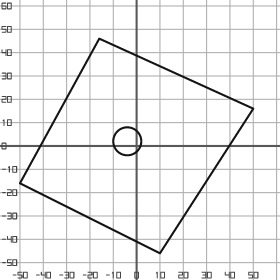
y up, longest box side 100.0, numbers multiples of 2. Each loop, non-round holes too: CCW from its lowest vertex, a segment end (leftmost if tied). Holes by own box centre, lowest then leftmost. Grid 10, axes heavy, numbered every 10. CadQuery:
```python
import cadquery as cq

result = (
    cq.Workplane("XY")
    .moveTo(10.0, -46.0)
    .lineTo(50.0, 16.0)
    .lineTo(-16.0, 46.0)
    .lineTo(-50.0, -16.0)
    .close()
    .moveTo(-4.0, 2.0)
    .circle(6.0)
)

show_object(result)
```